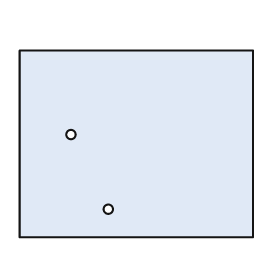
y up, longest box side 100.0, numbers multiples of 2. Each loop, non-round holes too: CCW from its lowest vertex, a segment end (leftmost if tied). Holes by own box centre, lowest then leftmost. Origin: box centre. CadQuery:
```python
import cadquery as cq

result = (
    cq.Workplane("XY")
    .moveTo(-50.0, -40.0)
    .lineTo(50.0, -40.0)
    .lineTo(50.0, 40.0)
    .lineTo(-50.0, 40.0)
    .close()
    .moveTo(-12.0, -28.0)
    .circle(2.0)
    .moveTo(-28.0, 4.0)
    .circle(2.0)
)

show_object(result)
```